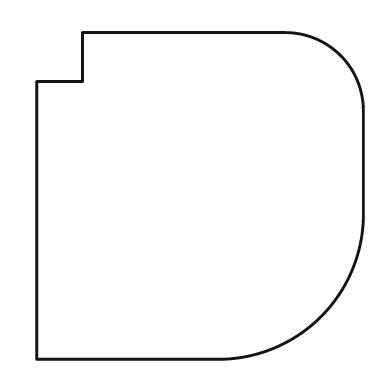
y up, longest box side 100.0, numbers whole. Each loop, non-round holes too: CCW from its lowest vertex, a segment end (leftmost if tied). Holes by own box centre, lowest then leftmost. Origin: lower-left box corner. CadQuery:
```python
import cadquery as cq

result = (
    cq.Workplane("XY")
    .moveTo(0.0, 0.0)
    .lineTo(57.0, 0.0)
    .threePointArc((87.0, 13.0), (100.0, 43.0))
    .lineTo(100.0, 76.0)
    .threePointArc((93.0, 93.0), (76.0, 100.0))
    .lineTo(14.0, 100.0)
    .lineTo(14.0, 85.0)
    .lineTo(0.0, 85.0)
    .close()
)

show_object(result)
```